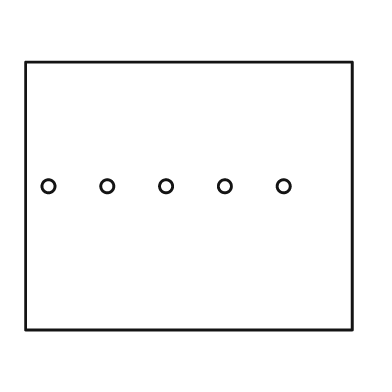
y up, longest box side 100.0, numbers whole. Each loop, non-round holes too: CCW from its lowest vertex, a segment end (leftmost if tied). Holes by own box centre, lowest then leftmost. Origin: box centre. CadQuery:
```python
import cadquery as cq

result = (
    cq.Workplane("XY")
    .moveTo(-50.0, -41.0)
    .lineTo(50.0, -41.0)
    .lineTo(50.0, 41.0)
    .lineTo(-50.0, 41.0)
    .close()
    .moveTo(-43.0, 3.0)
    .circle(2.0)
    .moveTo(-25.0, 3.0)
    .circle(2.0)
    .moveTo(-7.0, 3.0)
    .circle(2.0)
    .moveTo(11.0, 3.0)
    .circle(2.0)
    .moveTo(29.0, 3.0)
    .circle(2.0)
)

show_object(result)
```